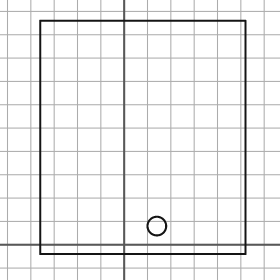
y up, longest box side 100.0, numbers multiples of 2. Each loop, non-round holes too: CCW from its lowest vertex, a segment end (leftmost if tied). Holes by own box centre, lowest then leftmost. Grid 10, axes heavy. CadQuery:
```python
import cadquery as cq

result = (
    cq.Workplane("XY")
    .moveTo(-36.0, -4.0)
    .lineTo(52.0, -4.0)
    .lineTo(52.0, 96.0)
    .lineTo(-36.0, 96.0)
    .close()
    .moveTo(14.0, 8.0)
    .circle(4.0)
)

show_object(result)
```